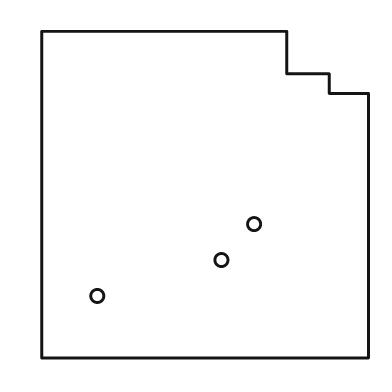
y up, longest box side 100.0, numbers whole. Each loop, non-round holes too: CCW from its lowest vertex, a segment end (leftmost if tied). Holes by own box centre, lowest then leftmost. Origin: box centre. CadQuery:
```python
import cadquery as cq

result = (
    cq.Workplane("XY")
    .moveTo(-50.0, -50.0)
    .lineTo(50.0, -50.0)
    .lineTo(50.0, 31.0)
    .lineTo(38.0, 31.0)
    .lineTo(38.0, 37.0)
    .lineTo(25.0, 37.0)
    .lineTo(25.0, 50.0)
    .lineTo(-50.0, 50.0)
    .close()
    .moveTo(-33.0, -31.0)
    .circle(2.0)
    .moveTo(5.0, -20.0)
    .circle(2.0)
    .moveTo(15.0, -9.0)
    .circle(2.0)
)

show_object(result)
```